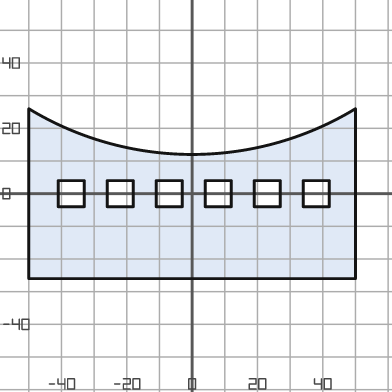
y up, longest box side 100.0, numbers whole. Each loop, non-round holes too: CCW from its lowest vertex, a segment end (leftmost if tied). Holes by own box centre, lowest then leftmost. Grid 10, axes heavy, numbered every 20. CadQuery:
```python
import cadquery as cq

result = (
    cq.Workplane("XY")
    .moveTo(-50.0, -26.0)
    .lineTo(50.0, -26.0)
    .lineTo(50.0, 26.0)
    .threePointArc((0.0, 12.0), (-50.0, 26.0))
    .close()
    .moveTo(-41.0, -4.0)
    .lineTo(-33.0, -4.0)
    .lineTo(-33.0, 4.0)
    .lineTo(-41.0, 4.0)
    .close()
    .moveTo(-26.0, -4.0)
    .lineTo(-18.0, -4.0)
    .lineTo(-18.0, 4.0)
    .lineTo(-26.0, 4.0)
    .close()
    .moveTo(-11.0, -4.0)
    .lineTo(-3.0, -4.0)
    .lineTo(-3.0, 4.0)
    .lineTo(-11.0, 4.0)
    .close()
    .moveTo(4.0, -4.0)
    .lineTo(12.0, -4.0)
    .lineTo(12.0, 4.0)
    .lineTo(4.0, 4.0)
    .close()
    .moveTo(19.0, -4.0)
    .lineTo(27.0, -4.0)
    .lineTo(27.0, 4.0)
    .lineTo(19.0, 4.0)
    .close()
    .moveTo(34.0, -4.0)
    .lineTo(42.0, -4.0)
    .lineTo(42.0, 4.0)
    .lineTo(34.0, 4.0)
    .close()
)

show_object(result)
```